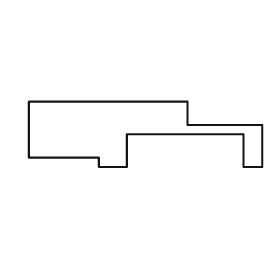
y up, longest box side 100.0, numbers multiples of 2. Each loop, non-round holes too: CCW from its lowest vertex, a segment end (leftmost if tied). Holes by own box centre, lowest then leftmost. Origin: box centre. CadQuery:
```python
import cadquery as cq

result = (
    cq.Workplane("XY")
    .moveTo(-20.0, -14.0)
    .lineTo(-8.0, -14.0)
    .lineTo(-8.0, 0.0)
    .lineTo(42.0, 0.0)
    .lineTo(42.0, -14.0)
    .lineTo(50.0, -14.0)
    .lineTo(50.0, 4.0)
    .lineTo(18.0, 4.0)
    .lineTo(18.0, 14.0)
    .lineTo(-50.0, 14.0)
    .lineTo(-50.0, -10.0)
    .lineTo(-20.0, -10.0)
    .close()
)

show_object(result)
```